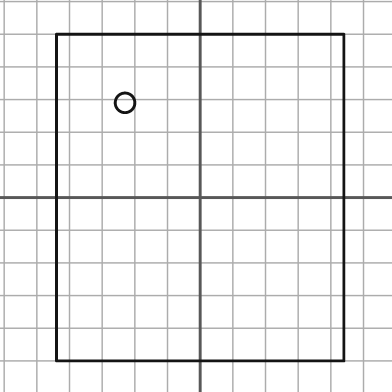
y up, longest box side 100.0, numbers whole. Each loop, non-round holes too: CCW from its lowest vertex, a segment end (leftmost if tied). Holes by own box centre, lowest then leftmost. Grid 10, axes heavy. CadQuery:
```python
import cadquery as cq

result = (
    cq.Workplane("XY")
    .moveTo(-44.0, -50.0)
    .lineTo(44.0, -50.0)
    .lineTo(44.0, 50.0)
    .lineTo(-44.0, 50.0)
    .close()
    .moveTo(-23.0, 29.0)
    .circle(3.0)
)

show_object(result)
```